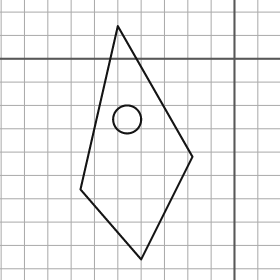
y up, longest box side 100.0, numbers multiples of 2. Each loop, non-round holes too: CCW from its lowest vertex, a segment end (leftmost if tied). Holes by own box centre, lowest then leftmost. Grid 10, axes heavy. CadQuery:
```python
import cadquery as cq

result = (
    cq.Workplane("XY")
    .moveTo(-40.0, -86.0)
    .lineTo(-18.0, -42.0)
    .lineTo(-50.0, 14.0)
    .lineTo(-66.0, -56.0)
    .close()
    .moveTo(-46.0, -26.0)
    .circle(6.0)
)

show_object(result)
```